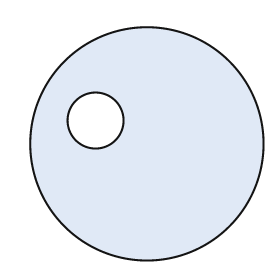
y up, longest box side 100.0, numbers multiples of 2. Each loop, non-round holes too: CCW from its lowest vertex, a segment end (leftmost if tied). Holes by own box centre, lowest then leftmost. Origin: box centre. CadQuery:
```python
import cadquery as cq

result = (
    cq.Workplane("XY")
    .moveTo(0.0, 0.0)
    .circle(50.0)
    .moveTo(-22.0, 10.0)
    .circle(12.0)
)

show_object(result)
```